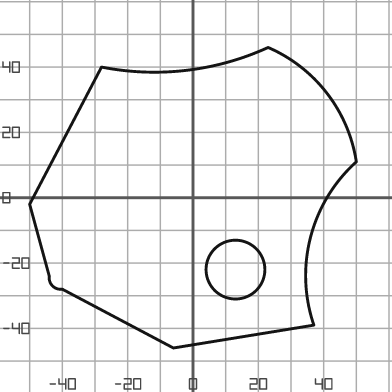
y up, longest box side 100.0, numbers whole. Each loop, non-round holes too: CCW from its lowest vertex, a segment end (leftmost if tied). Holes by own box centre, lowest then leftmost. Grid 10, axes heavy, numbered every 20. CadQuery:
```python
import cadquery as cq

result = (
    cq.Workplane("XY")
    .moveTo(-6.0, -46.0)
    .lineTo(37.0, -39.0)
    .threePointArc((36.0, -12.0), (50.0, 11.0))
    .threePointArc((41.0, 32.0), (23.0, 46.0))
    .threePointArc((-2.0, 39.0), (-28.0, 40.0))
    .lineTo(-50.0, -2.0)
    .lineTo(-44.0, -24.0)
    .threePointArc((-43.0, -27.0), (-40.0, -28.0))
    .close()
    .moveTo(13.0, -22.0)
    .circle(9.0)
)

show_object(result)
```